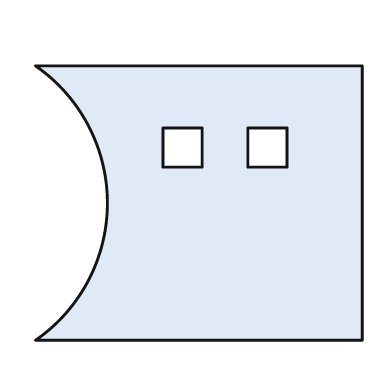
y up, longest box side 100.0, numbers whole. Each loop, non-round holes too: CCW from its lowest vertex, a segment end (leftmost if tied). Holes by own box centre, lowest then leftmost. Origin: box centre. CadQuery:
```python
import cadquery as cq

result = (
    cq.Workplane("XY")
    .moveTo(-50.0, -42.0)
    .lineTo(50.0, -42.0)
    .lineTo(50.0, 42.0)
    .lineTo(-50.0, 42.0)
    .threePointArc((-28.0, 0.0), (-50.0, -42.0))
    .close()
    .moveTo(-11.0, 11.0)
    .lineTo(1.0, 11.0)
    .lineTo(1.0, 23.0)
    .lineTo(-11.0, 23.0)
    .close()
    .moveTo(15.0, 11.0)
    .lineTo(27.0, 11.0)
    .lineTo(27.0, 23.0)
    .lineTo(15.0, 23.0)
    .close()
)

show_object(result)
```